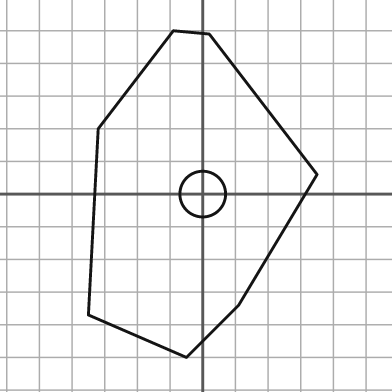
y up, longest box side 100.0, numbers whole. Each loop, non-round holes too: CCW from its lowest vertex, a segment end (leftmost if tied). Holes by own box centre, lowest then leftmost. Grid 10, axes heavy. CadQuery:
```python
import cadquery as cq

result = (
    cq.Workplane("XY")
    .moveTo(-5.0, -50.0)
    .lineTo(11.0, -34.0)
    .lineTo(35.0, 6.0)
    .lineTo(2.0, 49.0)
    .lineTo(-9.0, 50.0)
    .lineTo(-32.0, 20.0)
    .lineTo(-35.0, -37.0)
    .close()
    .moveTo(0.0, 0.0)
    .circle(7.0)
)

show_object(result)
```